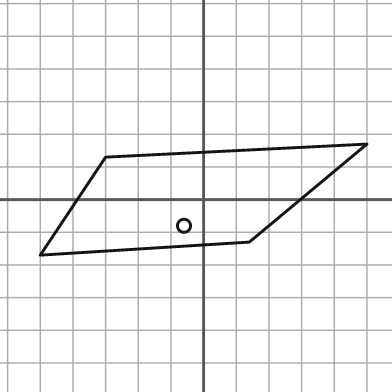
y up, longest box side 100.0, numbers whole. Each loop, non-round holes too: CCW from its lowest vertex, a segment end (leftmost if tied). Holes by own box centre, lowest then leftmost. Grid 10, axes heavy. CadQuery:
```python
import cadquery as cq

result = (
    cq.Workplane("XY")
    .moveTo(-50.0, -17.0)
    .lineTo(14.0, -13.0)
    .lineTo(50.0, 17.0)
    .lineTo(-30.0, 13.0)
    .close()
    .moveTo(-6.0, -8.0)
    .circle(2.0)
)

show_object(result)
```